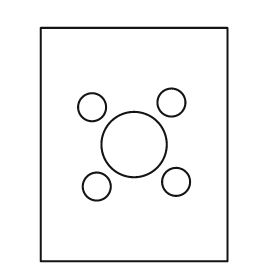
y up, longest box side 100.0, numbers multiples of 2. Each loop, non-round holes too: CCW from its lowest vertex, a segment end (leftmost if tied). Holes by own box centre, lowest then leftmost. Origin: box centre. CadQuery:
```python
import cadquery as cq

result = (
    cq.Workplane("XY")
    .moveTo(-40.0, -50.0)
    .lineTo(40.0, -50.0)
    .lineTo(40.0, 50.0)
    .lineTo(-40.0, 50.0)
    .close()
    .moveTo(-16.0, -18.0)
    .circle(6.0)
    .moveTo(18.0, -16.0)
    .circle(6.0)
    .moveTo(0.0, 0.0)
    .circle(14.0)
    .moveTo(-18.0, 16.0)
    .circle(6.0)
    .moveTo(16.0, 18.0)
    .circle(6.0)
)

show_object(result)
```